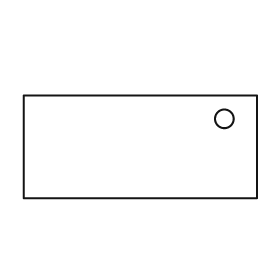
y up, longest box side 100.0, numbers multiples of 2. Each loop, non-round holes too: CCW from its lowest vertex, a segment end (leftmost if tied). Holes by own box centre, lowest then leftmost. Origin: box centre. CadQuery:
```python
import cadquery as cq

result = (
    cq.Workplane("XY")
    .moveTo(-50.0, -22.0)
    .lineTo(50.0, -22.0)
    .lineTo(50.0, 22.0)
    .lineTo(-50.0, 22.0)
    .close()
    .moveTo(36.0, 12.0)
    .circle(4.0)
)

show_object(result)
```